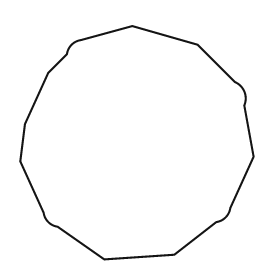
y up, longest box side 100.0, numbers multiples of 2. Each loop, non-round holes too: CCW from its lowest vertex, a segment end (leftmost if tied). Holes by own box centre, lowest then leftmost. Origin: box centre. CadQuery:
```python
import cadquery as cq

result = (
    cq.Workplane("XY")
    .moveTo(-14.0, -50.0)
    .lineTo(16.0, -48.0)
    .lineTo(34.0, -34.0)
    .threePointArc((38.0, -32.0), (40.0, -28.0))
    .lineTo(50.0, -6.0)
    .lineTo(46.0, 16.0)
    .threePointArc((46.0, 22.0), (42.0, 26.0))
    .lineTo(26.0, 42.0)
    .lineTo(-2.0, 50.0)
    .lineTo(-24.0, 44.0)
    .threePointArc((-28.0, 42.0), (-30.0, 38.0))
    .lineTo(-38.0, 30.0)
    .lineTo(-48.0, 8.0)
    .lineTo(-50.0, -8.0)
    .lineTo(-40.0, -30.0)
    .threePointArc((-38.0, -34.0), (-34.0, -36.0))
    .close()
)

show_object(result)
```